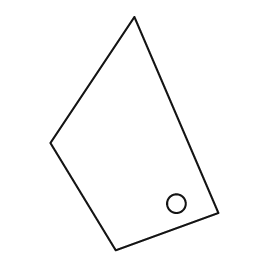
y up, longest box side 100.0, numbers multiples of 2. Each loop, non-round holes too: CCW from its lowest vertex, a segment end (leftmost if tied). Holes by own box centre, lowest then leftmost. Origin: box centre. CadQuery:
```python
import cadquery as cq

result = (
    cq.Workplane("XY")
    .moveTo(-8.0, -50.0)
    .lineTo(36.0, -34.0)
    .lineTo(0.0, 50.0)
    .lineTo(-36.0, -4.0)
    .close()
    .moveTo(18.0, -30.0)
    .circle(4.0)
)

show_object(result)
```